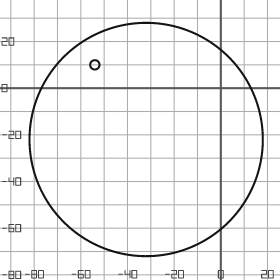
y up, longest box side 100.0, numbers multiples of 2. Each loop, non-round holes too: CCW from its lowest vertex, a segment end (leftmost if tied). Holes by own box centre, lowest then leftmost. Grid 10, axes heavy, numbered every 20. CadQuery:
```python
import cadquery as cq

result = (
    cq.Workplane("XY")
    .moveTo(-32.0, -22.0)
    .circle(50.0)
    .moveTo(-54.0, 10.0)
    .circle(2.0)
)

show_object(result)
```